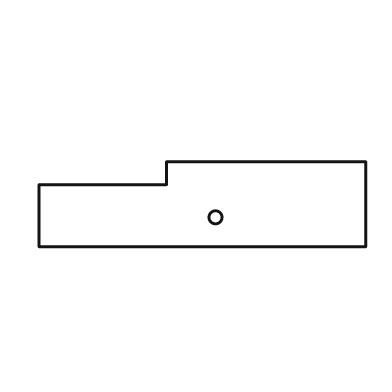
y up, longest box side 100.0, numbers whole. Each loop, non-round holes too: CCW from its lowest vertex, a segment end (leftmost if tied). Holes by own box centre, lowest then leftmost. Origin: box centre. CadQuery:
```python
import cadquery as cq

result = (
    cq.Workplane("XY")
    .moveTo(-50.0, -13.0)
    .lineTo(50.0, -13.0)
    .lineTo(50.0, 13.0)
    .lineTo(-11.0, 13.0)
    .lineTo(-11.0, 6.0)
    .lineTo(-50.0, 6.0)
    .close()
    .moveTo(4.0, -4.0)
    .circle(2.0)
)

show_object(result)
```